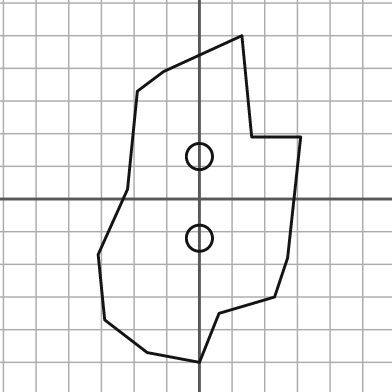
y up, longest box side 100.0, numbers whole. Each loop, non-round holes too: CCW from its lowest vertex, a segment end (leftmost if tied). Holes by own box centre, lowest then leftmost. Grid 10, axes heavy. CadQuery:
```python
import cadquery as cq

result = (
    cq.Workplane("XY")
    .moveTo(0.0, -50.0)
    .lineTo(6.0, -35.0)
    .lineTo(23.0, -30.0)
    .lineTo(27.0, -18.0)
    .lineTo(31.0, 19.0)
    .lineTo(16.0, 19.0)
    .lineTo(13.0, 50.0)
    .lineTo(-11.0, 39.0)
    .lineTo(-19.0, 33.0)
    .lineTo(-22.0, 3.0)
    .lineTo(-31.0, -17.0)
    .lineTo(-29.0, -37.0)
    .lineTo(-16.0, -47.0)
    .close()
    .moveTo(0.0, -12.0)
    .circle(4.0)
    .moveTo(0.0, 13.0)
    .circle(4.0)
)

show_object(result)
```